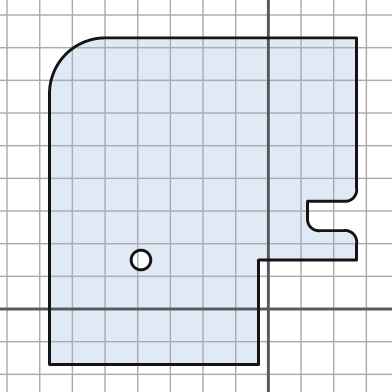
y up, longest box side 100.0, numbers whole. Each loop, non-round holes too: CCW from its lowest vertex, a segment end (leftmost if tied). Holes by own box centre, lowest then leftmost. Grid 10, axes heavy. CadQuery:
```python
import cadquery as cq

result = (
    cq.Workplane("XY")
    .moveTo(-67.0, -17.0)
    .lineTo(-3.0, -17.0)
    .lineTo(-3.0, 15.0)
    .lineTo(27.0, 15.0)
    .lineTo(27.0, 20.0)
    .threePointArc((26.0, 23.0), (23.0, 24.0))
    .lineTo(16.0, 24.0)
    .threePointArc((13.0, 25.0), (12.0, 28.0))
    .lineTo(12.0, 33.0)
    .lineTo(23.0, 33.0)
    .threePointArc((26.0, 34.0), (27.0, 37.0))
    .lineTo(27.0, 83.0)
    .lineTo(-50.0, 83.0)
    .threePointArc((-62.0, 78.0), (-67.0, 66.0))
    .close()
    .moveTo(-39.0, 15.0)
    .circle(3.0)
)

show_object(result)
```